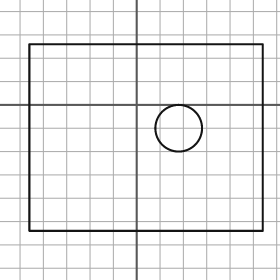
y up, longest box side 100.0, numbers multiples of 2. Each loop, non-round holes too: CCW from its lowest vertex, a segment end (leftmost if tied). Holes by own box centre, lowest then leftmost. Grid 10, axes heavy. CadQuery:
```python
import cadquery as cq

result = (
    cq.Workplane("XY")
    .moveTo(-46.0, -54.0)
    .lineTo(54.0, -54.0)
    .lineTo(54.0, 26.0)
    .lineTo(-46.0, 26.0)
    .close()
    .moveTo(18.0, -10.0)
    .circle(10.0)
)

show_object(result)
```